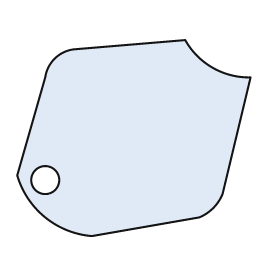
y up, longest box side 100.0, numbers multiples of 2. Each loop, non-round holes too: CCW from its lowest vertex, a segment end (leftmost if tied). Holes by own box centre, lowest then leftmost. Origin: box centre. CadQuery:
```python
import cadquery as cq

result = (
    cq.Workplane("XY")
    .moveTo(-18.0, -42.0)
    .lineTo(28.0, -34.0)
    .threePointArc((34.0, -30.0), (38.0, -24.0))
    .lineTo(50.0, 26.0)
    .threePointArc((34.0, 30.0), (22.0, 42.0))
    .lineTo(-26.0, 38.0)
    .threePointArc((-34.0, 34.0), (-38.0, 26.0))
    .lineTo(-50.0, -16.0)
    .threePointArc((-38.0, -34.0), (-18.0, -42.0))
    .close()
    .moveTo(-38.0, -18.0)
    .circle(6.0)
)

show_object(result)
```